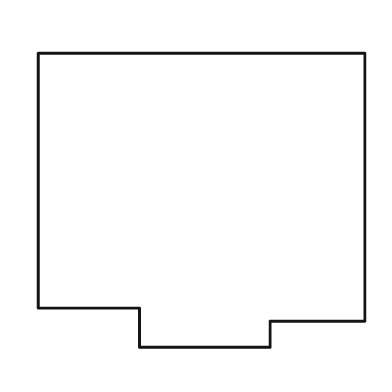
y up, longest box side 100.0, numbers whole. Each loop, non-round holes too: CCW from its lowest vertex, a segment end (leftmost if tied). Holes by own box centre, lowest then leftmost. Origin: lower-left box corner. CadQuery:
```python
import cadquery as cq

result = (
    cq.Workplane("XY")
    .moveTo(31.0, 0.0)
    .lineTo(71.0, 0.0)
    .lineTo(71.0, 8.0)
    .lineTo(100.0, 8.0)
    .lineTo(100.0, 90.0)
    .lineTo(0.0, 90.0)
    .lineTo(0.0, 12.0)
    .lineTo(31.0, 12.0)
    .close()
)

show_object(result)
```